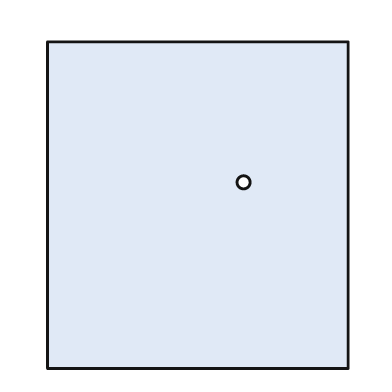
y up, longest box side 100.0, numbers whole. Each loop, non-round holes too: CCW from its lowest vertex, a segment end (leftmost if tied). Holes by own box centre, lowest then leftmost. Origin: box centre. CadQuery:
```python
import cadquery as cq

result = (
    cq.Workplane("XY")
    .moveTo(-46.0, -50.0)
    .lineTo(46.0, -50.0)
    .lineTo(46.0, 50.0)
    .lineTo(-46.0, 50.0)
    .close()
    .moveTo(14.0, 7.0)
    .circle(2.0)
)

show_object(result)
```